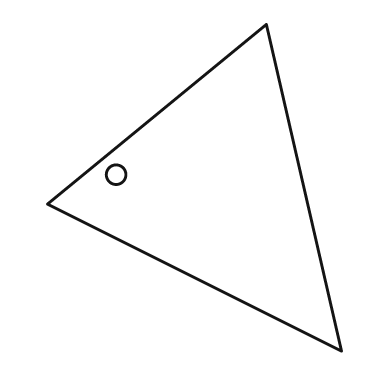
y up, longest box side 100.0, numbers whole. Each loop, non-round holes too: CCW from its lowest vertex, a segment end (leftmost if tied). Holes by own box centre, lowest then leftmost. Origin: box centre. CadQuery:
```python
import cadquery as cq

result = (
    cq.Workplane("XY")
    .moveTo(45.0, -50.0)
    .lineTo(22.0, 50.0)
    .lineTo(-45.0, -5.0)
    .close()
    .moveTo(-24.0, 4.0)
    .circle(3.0)
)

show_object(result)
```